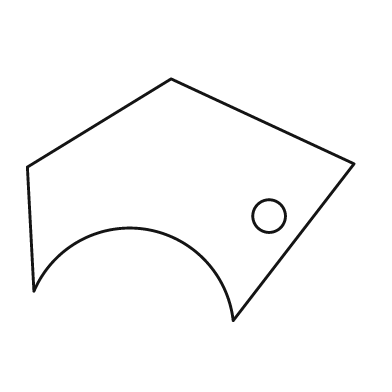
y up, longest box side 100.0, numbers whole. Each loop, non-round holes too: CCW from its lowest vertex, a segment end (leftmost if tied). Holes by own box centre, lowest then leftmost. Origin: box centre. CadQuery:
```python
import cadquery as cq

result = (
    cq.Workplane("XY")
    .moveTo(13.0, -37.0)
    .lineTo(50.0, 11.0)
    .lineTo(-6.0, 37.0)
    .lineTo(-50.0, 10.0)
    .lineTo(-48.0, -28.0)
    .threePointArc((-14.0, -9.0), (13.0, -37.0))
    .close()
    .moveTo(24.0, -5.0)
    .circle(5.0)
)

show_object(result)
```